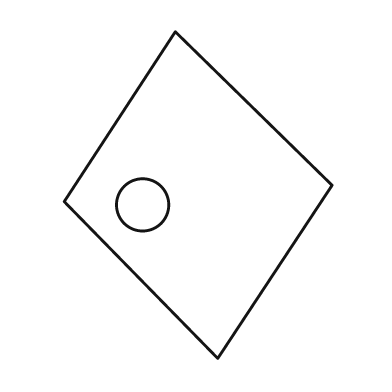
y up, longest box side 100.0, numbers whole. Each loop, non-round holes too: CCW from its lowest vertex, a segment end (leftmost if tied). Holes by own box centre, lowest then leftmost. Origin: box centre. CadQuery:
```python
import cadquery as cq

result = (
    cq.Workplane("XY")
    .moveTo(6.0, -50.0)
    .lineTo(41.0, 3.0)
    .lineTo(-7.0, 50.0)
    .lineTo(-41.0, -2.0)
    .close()
    .moveTo(-17.0, -3.0)
    .circle(8.0)
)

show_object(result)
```